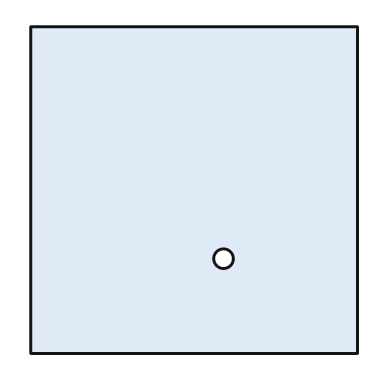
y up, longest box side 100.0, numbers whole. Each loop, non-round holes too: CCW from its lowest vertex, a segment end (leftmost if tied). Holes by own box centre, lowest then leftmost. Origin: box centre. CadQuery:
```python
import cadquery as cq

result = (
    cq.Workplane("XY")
    .moveTo(-50.0, -50.0)
    .lineTo(50.0, -50.0)
    .lineTo(50.0, 50.0)
    .lineTo(-50.0, 50.0)
    .close()
    .moveTo(9.0, -21.0)
    .circle(3.0)
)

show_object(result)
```